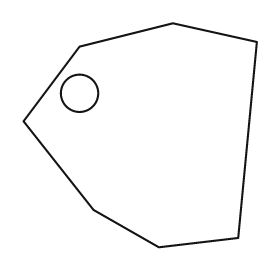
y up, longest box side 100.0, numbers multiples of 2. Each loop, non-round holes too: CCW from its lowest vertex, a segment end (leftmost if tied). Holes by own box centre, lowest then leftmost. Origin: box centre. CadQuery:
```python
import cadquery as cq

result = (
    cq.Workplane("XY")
    .moveTo(8.0, -48.0)
    .lineTo(42.0, -44.0)
    .lineTo(50.0, 40.0)
    .lineTo(14.0, 48.0)
    .lineTo(-26.0, 38.0)
    .lineTo(-50.0, 6.0)
    .lineTo(-20.0, -32.0)
    .close()
    .moveTo(-26.0, 18.0)
    .circle(8.0)
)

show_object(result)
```